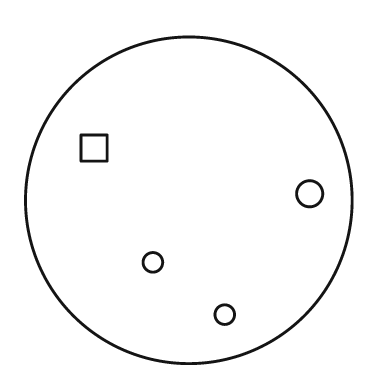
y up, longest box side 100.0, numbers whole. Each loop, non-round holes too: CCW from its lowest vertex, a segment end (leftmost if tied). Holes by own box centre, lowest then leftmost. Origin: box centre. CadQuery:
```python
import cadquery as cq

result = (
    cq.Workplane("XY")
    .moveTo(0.0, 0.0)
    .circle(50.0)
    .moveTo(11.0, -35.0)
    .circle(3.0)
    .moveTo(-11.0, -19.0)
    .circle(3.0)
    .moveTo(37.0, 2.0)
    .circle(4.0)
    .moveTo(-33.0, 12.0)
    .lineTo(-25.0, 12.0)
    .lineTo(-25.0, 20.0)
    .lineTo(-33.0, 20.0)
    .close()
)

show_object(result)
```